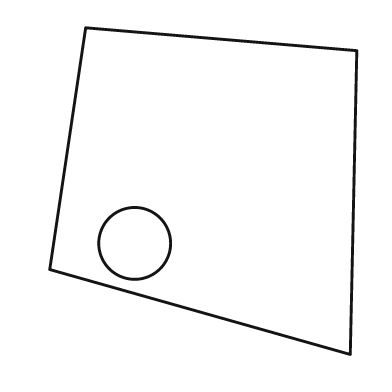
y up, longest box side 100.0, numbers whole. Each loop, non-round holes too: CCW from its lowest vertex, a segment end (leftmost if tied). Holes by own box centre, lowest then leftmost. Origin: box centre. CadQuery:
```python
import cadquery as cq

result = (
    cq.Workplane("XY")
    .moveTo(45.0, -50.0)
    .lineTo(47.0, 43.0)
    .lineTo(-36.0, 50.0)
    .lineTo(-47.0, -24.0)
    .close()
    .moveTo(-21.0, -16.0)
    .circle(11.0)
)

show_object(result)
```